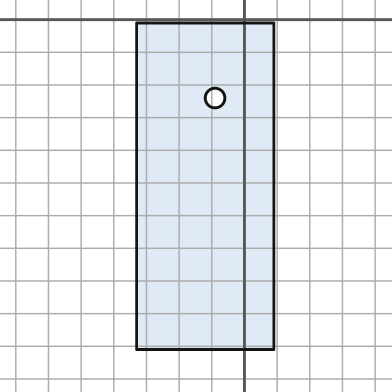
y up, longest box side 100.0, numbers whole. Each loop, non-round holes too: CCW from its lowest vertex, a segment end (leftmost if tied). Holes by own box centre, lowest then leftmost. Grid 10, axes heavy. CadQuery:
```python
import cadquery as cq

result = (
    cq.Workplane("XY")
    .moveTo(-33.0, -101.0)
    .lineTo(9.0, -101.0)
    .lineTo(9.0, -1.0)
    .lineTo(-33.0, -1.0)
    .close()
    .moveTo(-9.0, -24.0)
    .circle(3.0)
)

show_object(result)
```